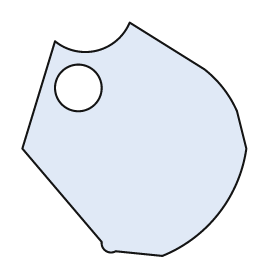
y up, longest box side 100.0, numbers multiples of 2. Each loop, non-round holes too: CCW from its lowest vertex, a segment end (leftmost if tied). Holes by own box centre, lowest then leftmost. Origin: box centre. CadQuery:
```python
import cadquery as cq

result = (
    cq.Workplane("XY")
    .moveTo(12.0, -50.0)
    .threePointArc((36.0, -32.0), (48.0, -4.0))
    .lineTo(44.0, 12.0)
    .threePointArc((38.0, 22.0), (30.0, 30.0))
    .lineTo(-2.0, 50.0)
    .threePointArc((-16.0, 38.0), (-34.0, 42.0))
    .lineTo(-48.0, -4.0)
    .lineTo(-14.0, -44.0)
    .threePointArc((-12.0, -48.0), (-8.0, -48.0))
    .close()
    .moveTo(-24.0, 22.0)
    .circle(10.0)
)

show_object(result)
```